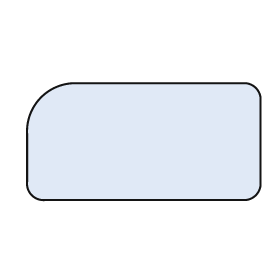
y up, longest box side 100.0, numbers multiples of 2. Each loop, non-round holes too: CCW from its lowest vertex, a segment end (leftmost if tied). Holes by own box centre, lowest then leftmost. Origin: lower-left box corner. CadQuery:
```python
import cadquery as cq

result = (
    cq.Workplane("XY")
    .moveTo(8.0, 0.0)
    .lineTo(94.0, 0.0)
    .threePointArc((98.0, 2.0), (100.0, 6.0))
    .lineTo(100.0, 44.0)
    .threePointArc((98.0, 48.0), (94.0, 50.0))
    .lineTo(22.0, 50.0)
    .threePointArc((6.0, 44.0), (0.0, 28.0))
    .lineTo(0.0, 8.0)
    .threePointArc((2.0, 2.0), (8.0, 0.0))
    .close()
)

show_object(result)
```